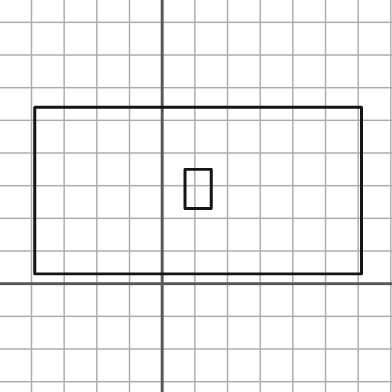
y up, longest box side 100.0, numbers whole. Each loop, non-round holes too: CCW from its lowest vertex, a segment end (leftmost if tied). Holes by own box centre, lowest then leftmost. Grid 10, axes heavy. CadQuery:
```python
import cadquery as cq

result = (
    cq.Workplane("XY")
    .moveTo(-39.0, 3.0)
    .lineTo(61.0, 3.0)
    .lineTo(61.0, 54.0)
    .lineTo(-39.0, 54.0)
    .close()
    .moveTo(7.0, 23.0)
    .lineTo(15.0, 23.0)
    .lineTo(15.0, 35.0)
    .lineTo(7.0, 35.0)
    .close()
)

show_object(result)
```